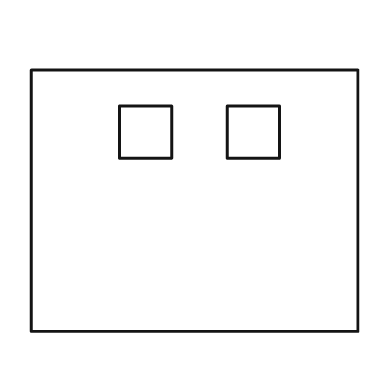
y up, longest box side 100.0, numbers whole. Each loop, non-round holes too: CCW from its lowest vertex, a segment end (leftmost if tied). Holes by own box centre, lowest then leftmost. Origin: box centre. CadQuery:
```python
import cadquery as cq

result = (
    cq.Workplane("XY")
    .moveTo(-50.0, -40.0)
    .lineTo(50.0, -40.0)
    .lineTo(50.0, 40.0)
    .lineTo(-50.0, 40.0)
    .close()
    .moveTo(-23.0, 13.0)
    .lineTo(-7.0, 13.0)
    .lineTo(-7.0, 29.0)
    .lineTo(-23.0, 29.0)
    .close()
    .moveTo(10.0, 13.0)
    .lineTo(26.0, 13.0)
    .lineTo(26.0, 29.0)
    .lineTo(10.0, 29.0)
    .close()
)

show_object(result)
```